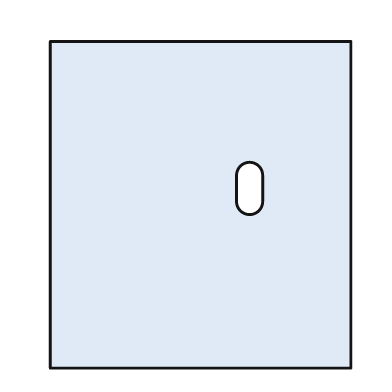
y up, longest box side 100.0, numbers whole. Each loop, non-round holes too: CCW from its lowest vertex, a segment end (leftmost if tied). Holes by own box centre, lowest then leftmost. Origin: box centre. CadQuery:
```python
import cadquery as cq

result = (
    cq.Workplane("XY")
    .moveTo(-46.0, -50.0)
    .lineTo(46.0, -50.0)
    .lineTo(46.0, 50.0)
    .lineTo(-46.0, 50.0)
    .close()
    .moveTo(11.0, 1.0)
    .threePointArc((15.0, -3.0), (19.0, 1.0))
    .lineTo(19.0, 9.0)
    .threePointArc((15.0, 13.0), (11.0, 9.0))
    .close()
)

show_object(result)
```